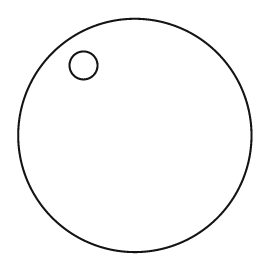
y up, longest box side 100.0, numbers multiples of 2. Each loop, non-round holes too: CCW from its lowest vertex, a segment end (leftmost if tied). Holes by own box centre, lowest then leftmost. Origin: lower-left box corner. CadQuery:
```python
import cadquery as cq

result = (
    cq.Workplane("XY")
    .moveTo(50.0, 50.0)
    .circle(50.0)
    .moveTo(28.0, 80.0)
    .circle(6.0)
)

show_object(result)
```